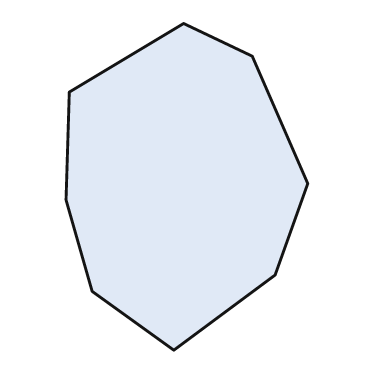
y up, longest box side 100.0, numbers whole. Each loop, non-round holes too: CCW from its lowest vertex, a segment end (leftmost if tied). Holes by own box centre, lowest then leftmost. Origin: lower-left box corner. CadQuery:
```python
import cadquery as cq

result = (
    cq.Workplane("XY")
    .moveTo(33.0, 0.0)
    .lineTo(64.0, 23.0)
    .lineTo(74.0, 51.0)
    .lineTo(57.0, 90.0)
    .lineTo(36.0, 100.0)
    .lineTo(1.0, 79.0)
    .lineTo(0.0, 46.0)
    .lineTo(8.0, 18.0)
    .close()
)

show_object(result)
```